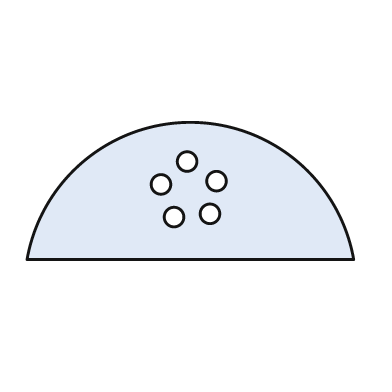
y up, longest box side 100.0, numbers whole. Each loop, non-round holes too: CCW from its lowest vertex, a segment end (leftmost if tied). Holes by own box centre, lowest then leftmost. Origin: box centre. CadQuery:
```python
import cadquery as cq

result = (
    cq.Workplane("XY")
    .moveTo(-50.0, -21.0)
    .lineTo(50.0, -21.0)
    .threePointArc((0.0, 21.0), (-50.0, -21.0))
    .close()
    .moveTo(-5.0, -8.0)
    .circle(3.0)
    .moveTo(6.0, -7.0)
    .circle(3.0)
    .moveTo(-9.0, 2.0)
    .circle(3.0)
    .moveTo(8.0, 3.0)
    .circle(3.0)
    .moveTo(-1.0, 9.0)
    .circle(3.0)
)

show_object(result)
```